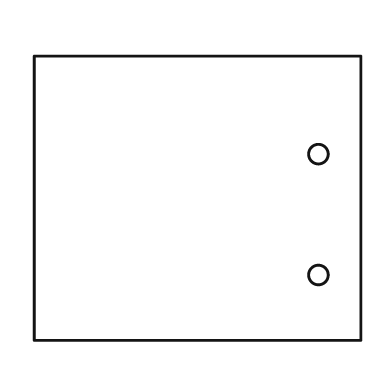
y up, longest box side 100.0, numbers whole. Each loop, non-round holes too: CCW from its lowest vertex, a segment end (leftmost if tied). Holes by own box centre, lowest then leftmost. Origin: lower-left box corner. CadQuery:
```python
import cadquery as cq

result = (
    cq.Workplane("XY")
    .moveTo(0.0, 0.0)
    .lineTo(100.0, 0.0)
    .lineTo(100.0, 87.0)
    .lineTo(0.0, 87.0)
    .close()
    .moveTo(87.0, 20.0)
    .circle(3.0)
    .moveTo(87.0, 57.0)
    .circle(3.0)
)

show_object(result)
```